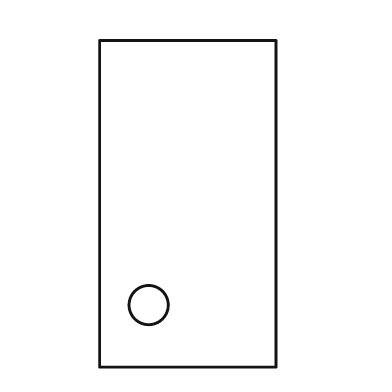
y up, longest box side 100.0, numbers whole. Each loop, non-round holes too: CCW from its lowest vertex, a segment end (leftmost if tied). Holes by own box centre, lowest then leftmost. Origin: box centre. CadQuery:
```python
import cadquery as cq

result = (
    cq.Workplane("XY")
    .moveTo(-27.0, -50.0)
    .lineTo(27.0, -50.0)
    .lineTo(27.0, 50.0)
    .lineTo(-27.0, 50.0)
    .close()
    .moveTo(-12.0, -31.0)
    .circle(6.0)
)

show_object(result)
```